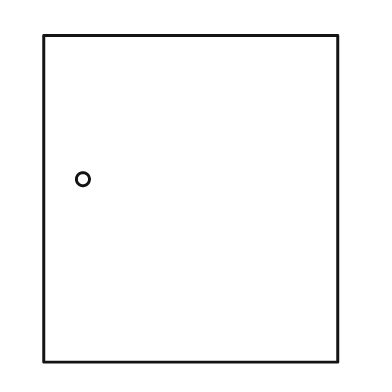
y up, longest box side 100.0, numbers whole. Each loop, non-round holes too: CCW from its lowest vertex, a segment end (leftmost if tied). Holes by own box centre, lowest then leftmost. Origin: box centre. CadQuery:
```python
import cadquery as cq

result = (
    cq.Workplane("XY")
    .moveTo(-45.0, -50.0)
    .lineTo(45.0, -50.0)
    .lineTo(45.0, 50.0)
    .lineTo(-45.0, 50.0)
    .close()
    .moveTo(-33.0, 6.0)
    .circle(2.0)
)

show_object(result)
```